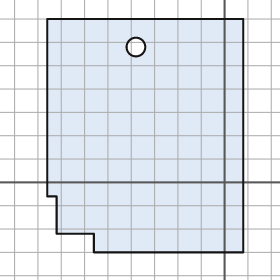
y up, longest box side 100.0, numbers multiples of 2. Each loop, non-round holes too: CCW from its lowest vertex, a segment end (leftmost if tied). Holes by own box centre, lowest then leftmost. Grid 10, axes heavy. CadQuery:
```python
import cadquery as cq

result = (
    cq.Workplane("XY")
    .moveTo(-56.0, -30.0)
    .lineTo(8.0, -30.0)
    .lineTo(8.0, 70.0)
    .lineTo(-76.0, 70.0)
    .lineTo(-76.0, -6.0)
    .lineTo(-72.0, -6.0)
    .lineTo(-72.0, -22.0)
    .lineTo(-56.0, -22.0)
    .close()
    .moveTo(-38.0, 58.0)
    .circle(4.0)
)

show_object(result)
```